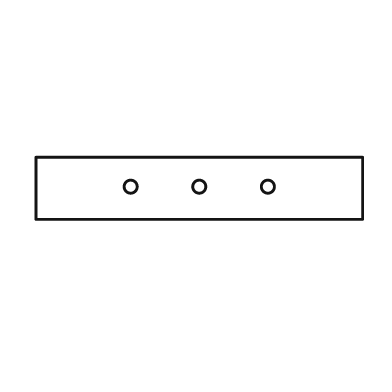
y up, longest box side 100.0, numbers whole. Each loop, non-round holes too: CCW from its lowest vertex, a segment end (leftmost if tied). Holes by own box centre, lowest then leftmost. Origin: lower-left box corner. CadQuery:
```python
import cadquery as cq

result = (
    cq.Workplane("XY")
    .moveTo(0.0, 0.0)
    .lineTo(100.0, 0.0)
    .lineTo(100.0, 19.0)
    .lineTo(0.0, 19.0)
    .close()
    .moveTo(29.0, 10.0)
    .circle(2.0)
    .moveTo(50.0, 10.0)
    .circle(2.0)
    .moveTo(71.0, 10.0)
    .circle(2.0)
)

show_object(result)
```